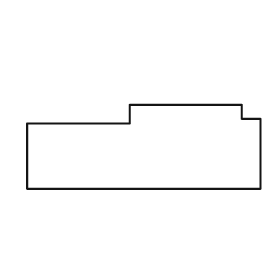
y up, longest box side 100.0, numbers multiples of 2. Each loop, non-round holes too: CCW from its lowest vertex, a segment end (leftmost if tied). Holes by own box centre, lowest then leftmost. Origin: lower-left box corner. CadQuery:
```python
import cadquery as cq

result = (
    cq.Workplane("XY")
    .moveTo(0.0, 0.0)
    .lineTo(100.0, 0.0)
    .lineTo(100.0, 30.0)
    .lineTo(92.0, 30.0)
    .lineTo(92.0, 36.0)
    .lineTo(44.0, 36.0)
    .lineTo(44.0, 28.0)
    .lineTo(0.0, 28.0)
    .close()
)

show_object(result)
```